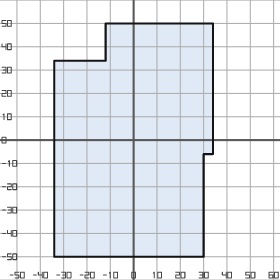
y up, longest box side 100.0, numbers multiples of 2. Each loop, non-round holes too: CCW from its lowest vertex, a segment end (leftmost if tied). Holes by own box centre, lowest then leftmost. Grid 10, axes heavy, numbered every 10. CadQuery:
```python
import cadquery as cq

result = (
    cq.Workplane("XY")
    .moveTo(-34.0, -50.0)
    .lineTo(30.0, -50.0)
    .lineTo(30.0, -6.0)
    .lineTo(34.0, -6.0)
    .lineTo(34.0, 50.0)
    .lineTo(-12.0, 50.0)
    .lineTo(-12.0, 34.0)
    .lineTo(-34.0, 34.0)
    .close()
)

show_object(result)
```